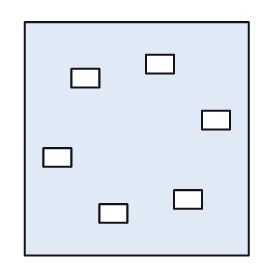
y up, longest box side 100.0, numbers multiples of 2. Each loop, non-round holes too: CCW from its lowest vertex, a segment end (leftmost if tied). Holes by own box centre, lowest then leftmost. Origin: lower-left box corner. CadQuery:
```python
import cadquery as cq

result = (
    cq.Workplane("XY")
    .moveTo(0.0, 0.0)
    .lineTo(96.0, 0.0)
    .lineTo(96.0, 100.0)
    .lineTo(0.0, 100.0)
    .close()
    .moveTo(32.0, 14.0)
    .lineTo(44.0, 14.0)
    .lineTo(44.0, 22.0)
    .lineTo(32.0, 22.0)
    .close()
    .moveTo(64.0, 20.0)
    .lineTo(76.0, 20.0)
    .lineTo(76.0, 28.0)
    .lineTo(64.0, 28.0)
    .close()
    .moveTo(8.0, 38.0)
    .lineTo(20.0, 38.0)
    .lineTo(20.0, 46.0)
    .lineTo(8.0, 46.0)
    .close()
    .moveTo(76.0, 54.0)
    .lineTo(88.0, 54.0)
    .lineTo(88.0, 62.0)
    .lineTo(76.0, 62.0)
    .close()
    .moveTo(20.0, 72.0)
    .lineTo(32.0, 72.0)
    .lineTo(32.0, 80.0)
    .lineTo(20.0, 80.0)
    .close()
    .moveTo(52.0, 78.0)
    .lineTo(64.0, 78.0)
    .lineTo(64.0, 86.0)
    .lineTo(52.0, 86.0)
    .close()
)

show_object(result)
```